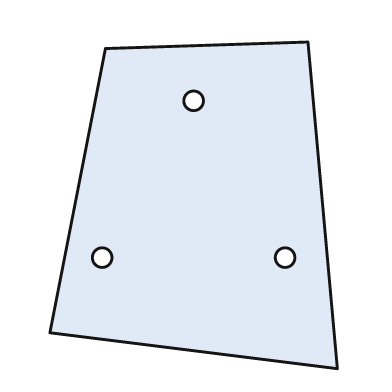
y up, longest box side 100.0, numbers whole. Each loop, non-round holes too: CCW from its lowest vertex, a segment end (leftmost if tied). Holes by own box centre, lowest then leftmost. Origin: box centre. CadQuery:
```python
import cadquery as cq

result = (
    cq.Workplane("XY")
    .moveTo(44.0, -50.0)
    .lineTo(35.0, 50.0)
    .lineTo(-27.0, 48.0)
    .lineTo(-44.0, -39.0)
    .close()
    .moveTo(-28.0, -16.0)
    .circle(3.0)
    .moveTo(28.0, -16.0)
    .circle(3.0)
    .moveTo(0.0, 32.0)
    .circle(3.0)
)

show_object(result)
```